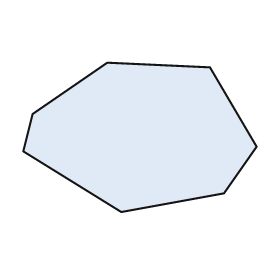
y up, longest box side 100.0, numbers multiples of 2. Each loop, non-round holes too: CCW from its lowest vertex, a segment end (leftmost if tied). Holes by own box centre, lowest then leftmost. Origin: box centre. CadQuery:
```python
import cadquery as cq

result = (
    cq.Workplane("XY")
    .moveTo(-8.0, -32.0)
    .lineTo(36.0, -24.0)
    .lineTo(50.0, -4.0)
    .lineTo(30.0, 30.0)
    .lineTo(-14.0, 32.0)
    .lineTo(-46.0, 10.0)
    .lineTo(-50.0, -6.0)
    .close()
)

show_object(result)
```